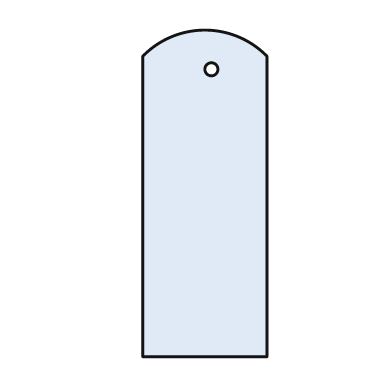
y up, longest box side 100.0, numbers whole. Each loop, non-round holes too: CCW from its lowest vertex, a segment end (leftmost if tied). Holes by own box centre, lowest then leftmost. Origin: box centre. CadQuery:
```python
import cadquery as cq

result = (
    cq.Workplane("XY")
    .moveTo(-19.0, -50.0)
    .lineTo(19.0, -50.0)
    .lineTo(19.0, 42.0)
    .threePointArc((0.0, 50.0), (-19.0, 42.0))
    .close()
    .moveTo(2.0, 38.0)
    .circle(2.0)
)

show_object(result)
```